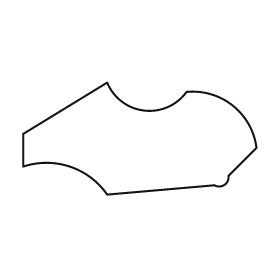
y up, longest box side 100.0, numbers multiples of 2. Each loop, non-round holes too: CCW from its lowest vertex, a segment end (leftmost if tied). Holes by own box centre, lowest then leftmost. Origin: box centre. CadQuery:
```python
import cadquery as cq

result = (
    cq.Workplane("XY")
    .moveTo(-14.0, -24.0)
    .lineTo(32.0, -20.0)
    .threePointArc((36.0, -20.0), (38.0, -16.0))
    .lineTo(50.0, -4.0)
    .threePointArc((40.0, 14.0), (20.0, 20.0))
    .threePointArc((2.0, 12.0), (-14.0, 24.0))
    .lineTo(-50.0, 2.0)
    .lineTo(-50.0, -12.0)
    .threePointArc((-30.0, -12.0), (-14.0, -24.0))
    .close()
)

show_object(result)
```